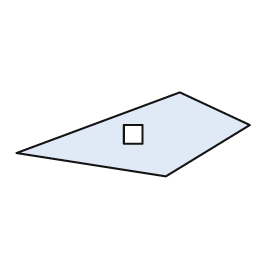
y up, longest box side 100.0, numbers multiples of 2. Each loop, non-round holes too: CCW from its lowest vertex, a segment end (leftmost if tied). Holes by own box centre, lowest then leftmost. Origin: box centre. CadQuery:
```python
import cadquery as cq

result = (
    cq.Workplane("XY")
    .moveTo(14.0, -18.0)
    .lineTo(50.0, 4.0)
    .lineTo(20.0, 18.0)
    .lineTo(-50.0, -8.0)
    .close()
    .moveTo(-4.0, -4.0)
    .lineTo(4.0, -4.0)
    .lineTo(4.0, 4.0)
    .lineTo(-4.0, 4.0)
    .close()
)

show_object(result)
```